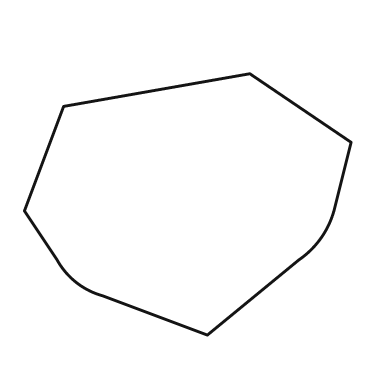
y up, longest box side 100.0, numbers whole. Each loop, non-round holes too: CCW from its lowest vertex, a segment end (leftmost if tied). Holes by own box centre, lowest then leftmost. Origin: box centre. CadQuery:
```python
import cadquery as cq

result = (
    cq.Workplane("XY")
    .moveTo(6.0, -40.0)
    .lineTo(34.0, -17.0)
    .threePointArc((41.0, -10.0), (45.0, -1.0))
    .lineTo(50.0, 19.0)
    .lineTo(19.0, 40.0)
    .lineTo(-38.0, 30.0)
    .lineTo(-50.0, -2.0)
    .lineTo(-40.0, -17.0)
    .threePointArc((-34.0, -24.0), (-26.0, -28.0))
    .close()
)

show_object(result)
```